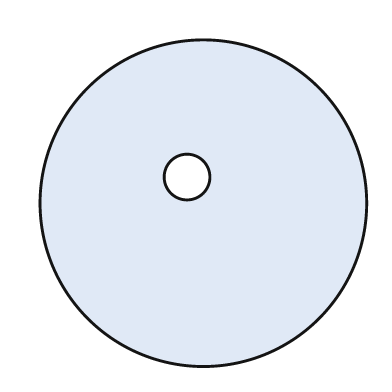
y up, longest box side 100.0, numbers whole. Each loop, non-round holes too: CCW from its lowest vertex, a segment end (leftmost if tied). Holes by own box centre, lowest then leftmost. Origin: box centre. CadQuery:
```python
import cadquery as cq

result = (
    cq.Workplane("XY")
    .moveTo(0.0, 0.0)
    .circle(50.0)
    .moveTo(-5.0, 8.0)
    .circle(7.0)
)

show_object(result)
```